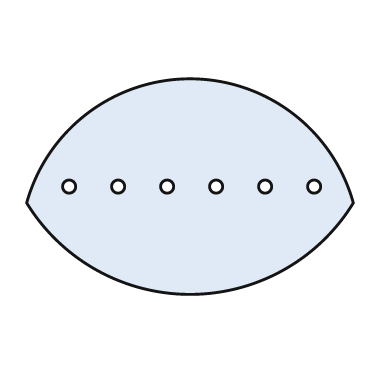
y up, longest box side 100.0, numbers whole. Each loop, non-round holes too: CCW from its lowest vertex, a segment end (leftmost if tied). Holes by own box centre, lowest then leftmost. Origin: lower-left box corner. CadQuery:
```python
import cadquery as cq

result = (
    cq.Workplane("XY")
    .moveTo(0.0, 28.0)
    .threePointArc((50.0, 0.0), (100.0, 28.0))
    .threePointArc((50.0, 66.0), (0.0, 28.0))
    .close()
    .moveTo(13.0, 33.0)
    .circle(2.0)
    .moveTo(28.0, 33.0)
    .circle(2.0)
    .moveTo(43.0, 33.0)
    .circle(2.0)
    .moveTo(58.0, 33.0)
    .circle(2.0)
    .moveTo(73.0, 33.0)
    .circle(2.0)
    .moveTo(88.0, 33.0)
    .circle(2.0)
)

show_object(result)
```